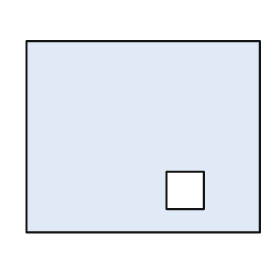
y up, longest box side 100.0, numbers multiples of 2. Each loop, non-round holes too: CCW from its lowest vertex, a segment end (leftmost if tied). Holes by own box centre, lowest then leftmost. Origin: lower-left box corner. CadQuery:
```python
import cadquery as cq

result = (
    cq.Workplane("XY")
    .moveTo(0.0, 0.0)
    .lineTo(100.0, 0.0)
    .lineTo(100.0, 82.0)
    .lineTo(0.0, 82.0)
    .close()
    .moveTo(60.0, 10.0)
    .lineTo(76.0, 10.0)
    .lineTo(76.0, 26.0)
    .lineTo(60.0, 26.0)
    .close()
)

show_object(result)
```